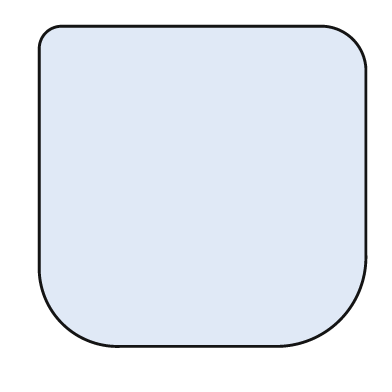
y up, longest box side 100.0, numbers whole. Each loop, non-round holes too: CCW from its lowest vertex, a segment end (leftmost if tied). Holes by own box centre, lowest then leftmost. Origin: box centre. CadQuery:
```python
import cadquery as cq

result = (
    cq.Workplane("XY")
    .moveTo(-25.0, -49.0)
    .lineTo(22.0, -49.0)
    .threePointArc((42.0, -41.0), (50.0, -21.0))
    .lineTo(50.0, 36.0)
    .threePointArc((46.0, 45.0), (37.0, 49.0))
    .lineTo(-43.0, 49.0)
    .threePointArc((-48.0, 47.0), (-50.0, 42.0))
    .lineTo(-50.0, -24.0)
    .threePointArc((-43.0, -42.0), (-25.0, -49.0))
    .close()
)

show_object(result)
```